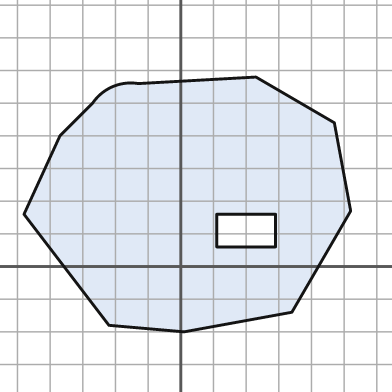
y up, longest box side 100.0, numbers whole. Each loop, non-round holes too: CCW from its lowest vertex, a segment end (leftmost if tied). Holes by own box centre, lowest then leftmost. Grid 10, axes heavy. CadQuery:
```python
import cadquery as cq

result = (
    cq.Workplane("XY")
    .moveTo(1.0, -20.0)
    .lineTo(34.0, -14.0)
    .lineTo(52.0, 17.0)
    .lineTo(47.0, 44.0)
    .lineTo(23.0, 58.0)
    .lineTo(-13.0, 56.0)
    .threePointArc((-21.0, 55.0), (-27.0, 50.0))
    .lineTo(-37.0, 40.0)
    .lineTo(-48.0, 16.0)
    .lineTo(-22.0, -18.0)
    .close()
    .moveTo(11.0, 6.0)
    .lineTo(29.0, 6.0)
    .lineTo(29.0, 16.0)
    .lineTo(11.0, 16.0)
    .close()
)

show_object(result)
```